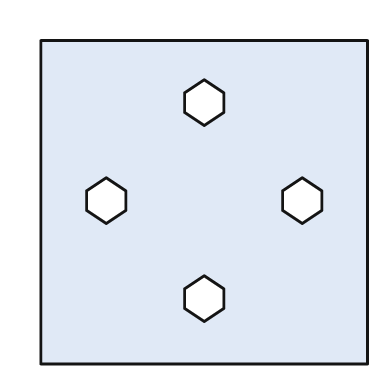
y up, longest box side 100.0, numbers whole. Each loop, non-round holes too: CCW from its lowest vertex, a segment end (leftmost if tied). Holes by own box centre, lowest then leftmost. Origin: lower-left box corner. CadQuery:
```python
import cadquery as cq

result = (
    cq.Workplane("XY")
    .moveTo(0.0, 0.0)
    .lineTo(100.0, 0.0)
    .lineTo(100.0, 99.0)
    .lineTo(0.0, 99.0)
    .close()
    .moveTo(50.0, 13.0)
    .lineTo(56.0, 17.0)
    .lineTo(56.0, 23.0)
    .lineTo(50.0, 27.0)
    .lineTo(44.0, 23.0)
    .lineTo(44.0, 17.0)
    .close()
    .moveTo(20.0, 43.0)
    .lineTo(26.0, 47.0)
    .lineTo(26.0, 53.0)
    .lineTo(20.0, 57.0)
    .lineTo(14.0, 53.0)
    .lineTo(14.0, 47.0)
    .close()
    .moveTo(80.0, 43.0)
    .lineTo(86.0, 47.0)
    .lineTo(86.0, 53.0)
    .lineTo(80.0, 57.0)
    .lineTo(74.0, 53.0)
    .lineTo(74.0, 47.0)
    .close()
    .moveTo(50.0, 73.0)
    .lineTo(56.0, 77.0)
    .lineTo(56.0, 83.0)
    .lineTo(50.0, 87.0)
    .lineTo(44.0, 83.0)
    .lineTo(44.0, 77.0)
    .close()
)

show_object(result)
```